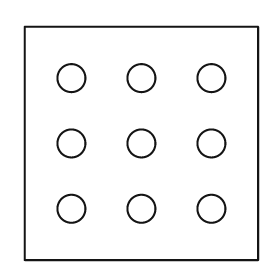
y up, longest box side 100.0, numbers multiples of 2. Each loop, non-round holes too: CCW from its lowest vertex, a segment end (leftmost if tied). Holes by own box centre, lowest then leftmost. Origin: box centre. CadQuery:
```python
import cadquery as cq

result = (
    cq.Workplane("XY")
    .moveTo(-50.0, -50.0)
    .lineTo(50.0, -50.0)
    .lineTo(50.0, 50.0)
    .lineTo(-50.0, 50.0)
    .close()
    .moveTo(-30.0, -28.0)
    .circle(6.0)
    .moveTo(0.0, -28.0)
    .circle(6.0)
    .moveTo(30.0, -28.0)
    .circle(6.0)
    .moveTo(-30.0, 0.0)
    .circle(6.0)
    .moveTo(0.0, 0.0)
    .circle(6.0)
    .moveTo(30.0, 0.0)
    .circle(6.0)
    .moveTo(-30.0, 28.0)
    .circle(6.0)
    .moveTo(0.0, 28.0)
    .circle(6.0)
    .moveTo(30.0, 28.0)
    .circle(6.0)
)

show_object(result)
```